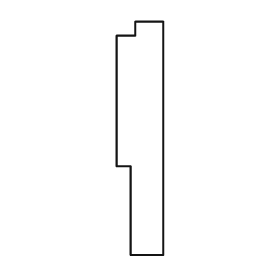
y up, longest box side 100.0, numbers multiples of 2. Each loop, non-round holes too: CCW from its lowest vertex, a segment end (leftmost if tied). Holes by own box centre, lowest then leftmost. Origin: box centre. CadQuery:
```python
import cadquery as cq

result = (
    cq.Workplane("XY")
    .moveTo(-4.0, -50.0)
    .lineTo(10.0, -50.0)
    .lineTo(10.0, 50.0)
    .lineTo(-2.0, 50.0)
    .lineTo(-2.0, 44.0)
    .lineTo(-10.0, 44.0)
    .lineTo(-10.0, -12.0)
    .lineTo(-4.0, -12.0)
    .close()
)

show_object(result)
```